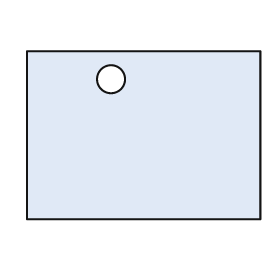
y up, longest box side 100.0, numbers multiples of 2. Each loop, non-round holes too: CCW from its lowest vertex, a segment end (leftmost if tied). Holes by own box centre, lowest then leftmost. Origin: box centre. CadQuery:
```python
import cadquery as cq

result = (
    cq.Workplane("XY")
    .moveTo(-50.0, -36.0)
    .lineTo(50.0, -36.0)
    .lineTo(50.0, 36.0)
    .lineTo(-50.0, 36.0)
    .close()
    .moveTo(-14.0, 24.0)
    .circle(6.0)
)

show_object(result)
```